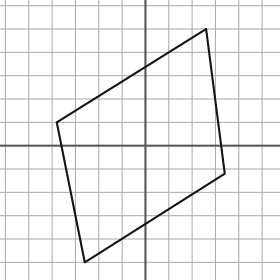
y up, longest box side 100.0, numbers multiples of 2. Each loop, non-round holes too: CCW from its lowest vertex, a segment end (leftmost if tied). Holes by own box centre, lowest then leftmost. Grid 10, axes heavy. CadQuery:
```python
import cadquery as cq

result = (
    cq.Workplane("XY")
    .moveTo(-26.0, -50.0)
    .lineTo(34.0, -12.0)
    .lineTo(26.0, 50.0)
    .lineTo(-38.0, 10.0)
    .close()
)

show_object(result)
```